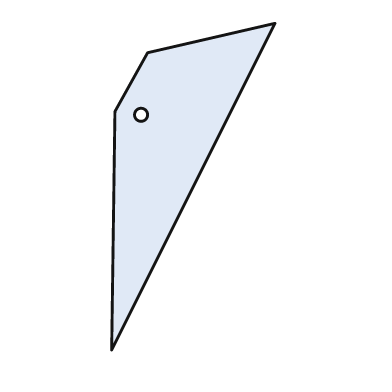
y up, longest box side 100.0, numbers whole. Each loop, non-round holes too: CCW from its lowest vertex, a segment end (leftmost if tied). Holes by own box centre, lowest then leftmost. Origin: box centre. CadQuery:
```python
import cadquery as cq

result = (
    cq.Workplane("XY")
    .moveTo(-25.0, -50.0)
    .lineTo(25.0, 50.0)
    .lineTo(-14.0, 41.0)
    .lineTo(-24.0, 23.0)
    .close()
    .moveTo(-16.0, 22.0)
    .circle(2.0)
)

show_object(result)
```